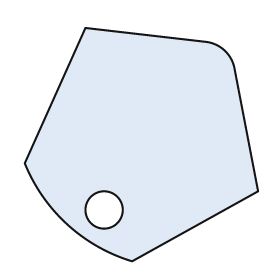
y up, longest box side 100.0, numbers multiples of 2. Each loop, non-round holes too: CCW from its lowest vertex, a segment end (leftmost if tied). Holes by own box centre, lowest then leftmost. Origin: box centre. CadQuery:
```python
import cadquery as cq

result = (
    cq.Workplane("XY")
    .moveTo(-4.0, -50.0)
    .lineTo(50.0, -20.0)
    .lineTo(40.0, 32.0)
    .threePointArc((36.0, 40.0), (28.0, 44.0))
    .lineTo(-24.0, 50.0)
    .lineTo(-50.0, -8.0)
    .threePointArc((-32.0, -34.0), (-4.0, -50.0))
    .close()
    .moveTo(-16.0, -28.0)
    .circle(8.0)
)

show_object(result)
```